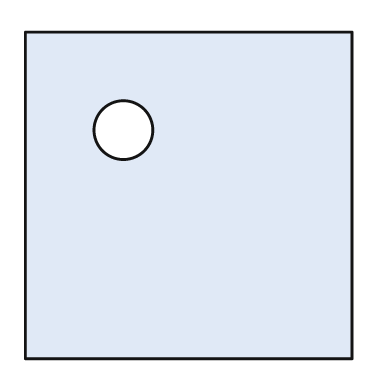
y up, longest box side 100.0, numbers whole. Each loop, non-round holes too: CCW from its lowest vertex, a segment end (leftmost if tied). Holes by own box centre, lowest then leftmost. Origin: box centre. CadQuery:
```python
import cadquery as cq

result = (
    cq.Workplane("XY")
    .moveTo(-50.0, -50.0)
    .lineTo(50.0, -50.0)
    .lineTo(50.0, 50.0)
    .lineTo(-50.0, 50.0)
    .close()
    .moveTo(-20.0, 20.0)
    .circle(9.0)
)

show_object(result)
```